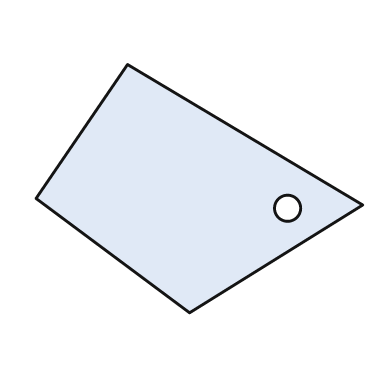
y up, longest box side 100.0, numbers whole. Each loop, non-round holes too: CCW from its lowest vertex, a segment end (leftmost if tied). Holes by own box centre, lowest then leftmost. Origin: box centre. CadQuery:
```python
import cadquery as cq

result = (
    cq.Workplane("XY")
    .moveTo(-3.0, -38.0)
    .lineTo(50.0, -5.0)
    .lineTo(-22.0, 38.0)
    .lineTo(-50.0, -3.0)
    .close()
    .moveTo(27.0, -6.0)
    .circle(4.0)
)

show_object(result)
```